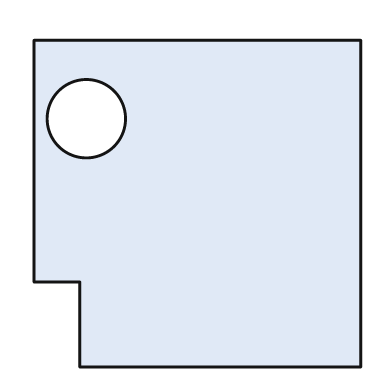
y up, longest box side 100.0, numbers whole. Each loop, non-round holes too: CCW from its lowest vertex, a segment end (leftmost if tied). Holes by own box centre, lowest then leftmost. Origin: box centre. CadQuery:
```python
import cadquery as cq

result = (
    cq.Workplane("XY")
    .moveTo(-36.0, -50.0)
    .lineTo(50.0, -50.0)
    .lineTo(50.0, 50.0)
    .lineTo(-50.0, 50.0)
    .lineTo(-50.0, -24.0)
    .lineTo(-36.0, -24.0)
    .close()
    .moveTo(-34.0, 26.0)
    .circle(12.0)
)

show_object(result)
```